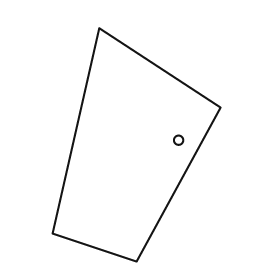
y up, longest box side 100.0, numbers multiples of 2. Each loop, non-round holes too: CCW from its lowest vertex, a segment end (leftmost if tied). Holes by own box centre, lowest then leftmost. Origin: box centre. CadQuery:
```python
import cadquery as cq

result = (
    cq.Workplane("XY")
    .moveTo(0.0, -50.0)
    .lineTo(36.0, 16.0)
    .lineTo(-16.0, 50.0)
    .lineTo(-36.0, -38.0)
    .close()
    .moveTo(18.0, 2.0)
    .circle(2.0)
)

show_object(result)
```